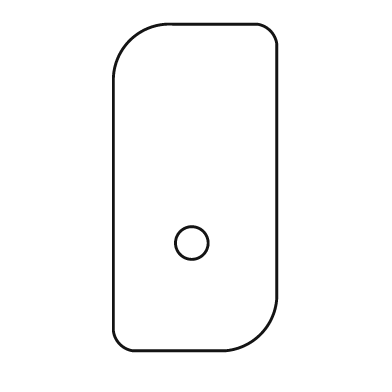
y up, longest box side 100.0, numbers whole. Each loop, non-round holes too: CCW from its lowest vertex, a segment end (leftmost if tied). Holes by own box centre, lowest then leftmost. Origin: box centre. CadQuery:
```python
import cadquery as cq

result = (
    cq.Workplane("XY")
    .moveTo(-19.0, -50.0)
    .lineTo(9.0, -50.0)
    .threePointArc((20.0, -45.0), (25.0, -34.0))
    .lineTo(25.0, 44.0)
    .threePointArc((23.0, 48.0), (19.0, 50.0))
    .lineTo(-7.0, 50.0)
    .threePointArc((-20.0, 45.0), (-25.0, 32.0))
    .lineTo(-25.0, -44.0)
    .threePointArc((-23.0, -48.0), (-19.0, -50.0))
    .close()
    .moveTo(-1.0, -17.0)
    .circle(5.0)
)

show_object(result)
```